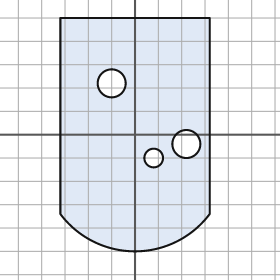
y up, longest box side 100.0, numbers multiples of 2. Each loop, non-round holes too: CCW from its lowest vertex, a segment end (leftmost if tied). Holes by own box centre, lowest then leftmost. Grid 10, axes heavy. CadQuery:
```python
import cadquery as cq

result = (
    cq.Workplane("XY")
    .moveTo(-32.0, -34.0)
    .threePointArc((0.0, -50.0), (32.0, -34.0))
    .lineTo(32.0, 50.0)
    .lineTo(-32.0, 50.0)
    .close()
    .moveTo(8.0, -10.0)
    .circle(4.0)
    .moveTo(22.0, -4.0)
    .circle(6.0)
    .moveTo(-10.0, 22.0)
    .circle(6.0)
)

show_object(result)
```